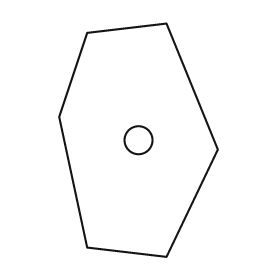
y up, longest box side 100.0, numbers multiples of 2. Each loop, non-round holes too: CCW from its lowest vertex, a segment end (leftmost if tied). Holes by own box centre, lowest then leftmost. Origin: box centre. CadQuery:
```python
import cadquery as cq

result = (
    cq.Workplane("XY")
    .moveTo(12.0, -50.0)
    .lineTo(34.0, -4.0)
    .lineTo(12.0, 50.0)
    .lineTo(-22.0, 46.0)
    .lineTo(-34.0, 10.0)
    .lineTo(-22.0, -46.0)
    .close()
    .moveTo(0.0, 0.0)
    .circle(6.0)
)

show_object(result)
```